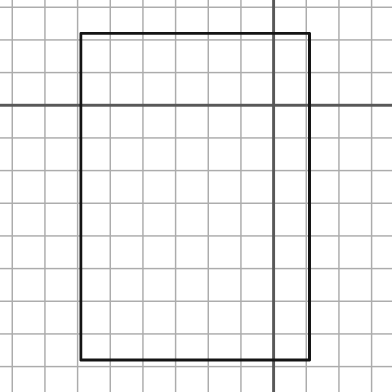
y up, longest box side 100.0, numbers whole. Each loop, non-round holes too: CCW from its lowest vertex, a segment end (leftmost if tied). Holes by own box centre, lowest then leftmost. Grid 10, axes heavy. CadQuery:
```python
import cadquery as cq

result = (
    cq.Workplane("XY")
    .moveTo(-59.0, -78.0)
    .lineTo(11.0, -78.0)
    .lineTo(11.0, 22.0)
    .lineTo(-59.0, 22.0)
    .close()
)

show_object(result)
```